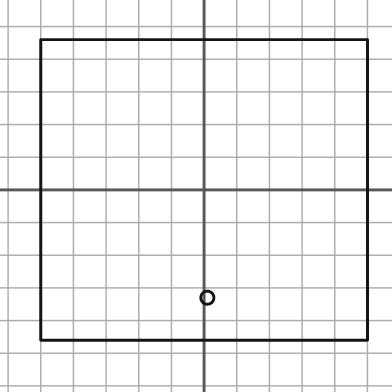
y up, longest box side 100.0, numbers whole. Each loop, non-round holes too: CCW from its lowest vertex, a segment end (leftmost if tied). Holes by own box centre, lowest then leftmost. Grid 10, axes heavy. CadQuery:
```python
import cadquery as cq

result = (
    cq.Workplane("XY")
    .moveTo(-50.0, -46.0)
    .lineTo(50.0, -46.0)
    .lineTo(50.0, 46.0)
    .lineTo(-50.0, 46.0)
    .close()
    .moveTo(1.0, -33.0)
    .circle(2.0)
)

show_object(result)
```